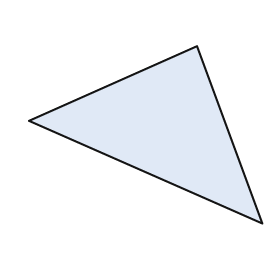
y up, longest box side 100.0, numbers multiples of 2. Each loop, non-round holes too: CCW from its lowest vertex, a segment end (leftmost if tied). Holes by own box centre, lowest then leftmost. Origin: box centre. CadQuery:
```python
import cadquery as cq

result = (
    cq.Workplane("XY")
    .moveTo(50.0, -38.0)
    .lineTo(22.0, 38.0)
    .lineTo(-50.0, 6.0)
    .close()
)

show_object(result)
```